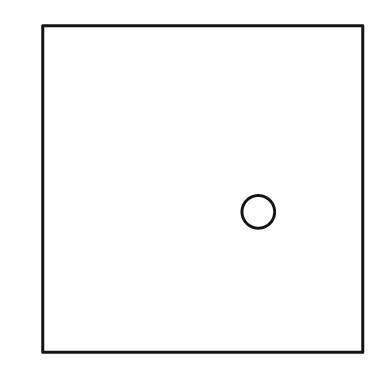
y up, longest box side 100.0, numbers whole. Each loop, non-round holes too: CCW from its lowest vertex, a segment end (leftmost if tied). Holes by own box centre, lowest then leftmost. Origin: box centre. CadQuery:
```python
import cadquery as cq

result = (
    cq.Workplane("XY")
    .moveTo(-49.0, -50.0)
    .lineTo(49.0, -50.0)
    .lineTo(49.0, 50.0)
    .lineTo(-49.0, 50.0)
    .close()
    .moveTo(17.0, -7.0)
    .circle(5.0)
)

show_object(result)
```